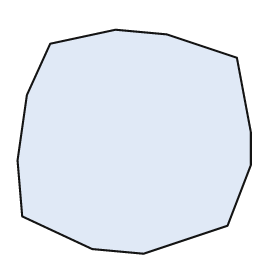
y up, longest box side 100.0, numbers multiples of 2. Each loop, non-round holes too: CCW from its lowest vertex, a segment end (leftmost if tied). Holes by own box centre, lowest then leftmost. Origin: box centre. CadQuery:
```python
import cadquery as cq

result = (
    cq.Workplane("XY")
    .moveTo(4.0, -48.0)
    .lineTo(40.0, -36.0)
    .lineTo(50.0, -10.0)
    .lineTo(50.0, 4.0)
    .lineTo(44.0, 36.0)
    .lineTo(14.0, 46.0)
    .lineTo(-8.0, 48.0)
    .lineTo(-36.0, 42.0)
    .lineTo(-46.0, 20.0)
    .lineTo(-50.0, -8.0)
    .lineTo(-48.0, -32.0)
    .lineTo(-18.0, -46.0)
    .close()
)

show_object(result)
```